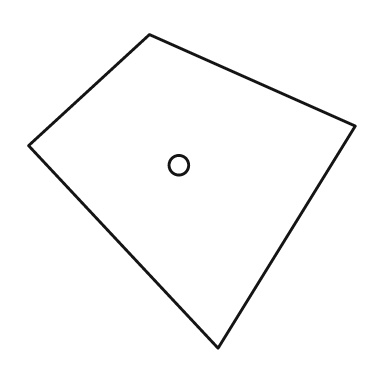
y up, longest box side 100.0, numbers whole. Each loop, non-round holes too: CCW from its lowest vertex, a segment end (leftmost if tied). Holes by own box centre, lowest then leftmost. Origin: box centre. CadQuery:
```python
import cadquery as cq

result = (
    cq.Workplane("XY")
    .moveTo(8.0, -48.0)
    .lineTo(50.0, 20.0)
    .lineTo(-13.0, 48.0)
    .lineTo(-50.0, 14.0)
    .close()
    .moveTo(-4.0, 8.0)
    .circle(3.0)
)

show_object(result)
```